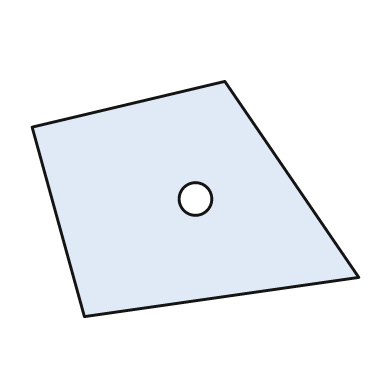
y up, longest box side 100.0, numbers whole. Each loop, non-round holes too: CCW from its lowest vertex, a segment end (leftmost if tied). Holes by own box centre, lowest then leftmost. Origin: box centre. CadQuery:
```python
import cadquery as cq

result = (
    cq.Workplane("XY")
    .moveTo(-34.0, -36.0)
    .lineTo(50.0, -24.0)
    .lineTo(9.0, 36.0)
    .lineTo(-50.0, 22.0)
    .close()
    .moveTo(0.0, 0.0)
    .circle(5.0)
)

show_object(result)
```